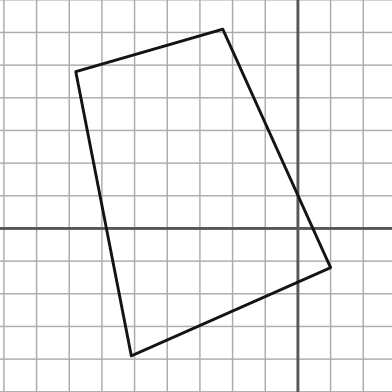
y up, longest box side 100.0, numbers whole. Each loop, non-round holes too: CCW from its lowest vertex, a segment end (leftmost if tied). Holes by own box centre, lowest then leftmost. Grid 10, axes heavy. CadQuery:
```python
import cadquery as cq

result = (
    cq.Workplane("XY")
    .moveTo(-51.0, -39.0)
    .lineTo(10.0, -12.0)
    .lineTo(-23.0, 61.0)
    .lineTo(-68.0, 48.0)
    .close()
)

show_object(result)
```